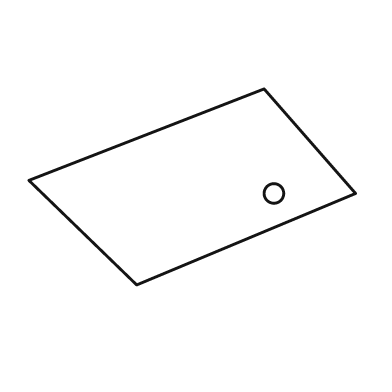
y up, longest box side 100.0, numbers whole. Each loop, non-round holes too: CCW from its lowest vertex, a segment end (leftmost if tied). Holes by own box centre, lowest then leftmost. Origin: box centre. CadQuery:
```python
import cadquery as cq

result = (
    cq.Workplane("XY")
    .moveTo(-17.0, -30.0)
    .lineTo(50.0, -2.0)
    .lineTo(22.0, 30.0)
    .lineTo(-50.0, 2.0)
    .close()
    .moveTo(25.0, -2.0)
    .circle(3.0)
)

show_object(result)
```